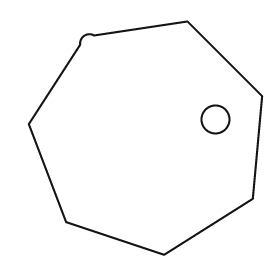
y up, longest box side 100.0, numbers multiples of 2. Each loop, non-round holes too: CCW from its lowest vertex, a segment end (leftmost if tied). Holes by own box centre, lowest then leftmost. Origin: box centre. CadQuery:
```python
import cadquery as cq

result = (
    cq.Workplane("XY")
    .moveTo(8.0, -50.0)
    .lineTo(46.0, -26.0)
    .lineTo(50.0, 18.0)
    .lineTo(18.0, 50.0)
    .lineTo(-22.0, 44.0)
    .threePointArc((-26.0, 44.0), (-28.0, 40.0))
    .lineTo(-50.0, 6.0)
    .lineTo(-34.0, -36.0)
    .close()
    .moveTo(30.0, 8.0)
    .circle(6.0)
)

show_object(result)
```